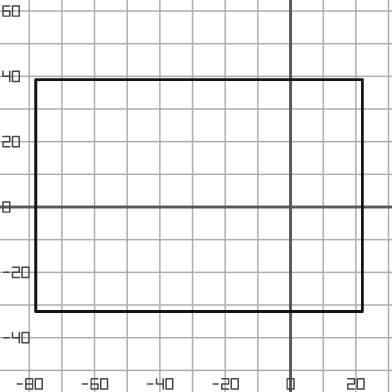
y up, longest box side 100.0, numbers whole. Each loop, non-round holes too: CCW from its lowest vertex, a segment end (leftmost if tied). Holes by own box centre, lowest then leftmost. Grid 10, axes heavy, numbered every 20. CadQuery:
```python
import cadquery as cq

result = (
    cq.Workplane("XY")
    .moveTo(-78.0, -32.0)
    .lineTo(22.0, -32.0)
    .lineTo(22.0, 39.0)
    .lineTo(-78.0, 39.0)
    .close()
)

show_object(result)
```